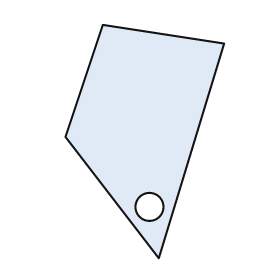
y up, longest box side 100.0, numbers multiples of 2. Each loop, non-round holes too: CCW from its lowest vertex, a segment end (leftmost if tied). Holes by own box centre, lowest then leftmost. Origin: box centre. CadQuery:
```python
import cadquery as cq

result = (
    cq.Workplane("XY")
    .moveTo(6.0, -50.0)
    .lineTo(34.0, 42.0)
    .lineTo(-18.0, 50.0)
    .lineTo(-34.0, 2.0)
    .close()
    .moveTo(2.0, -28.0)
    .circle(6.0)
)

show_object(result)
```